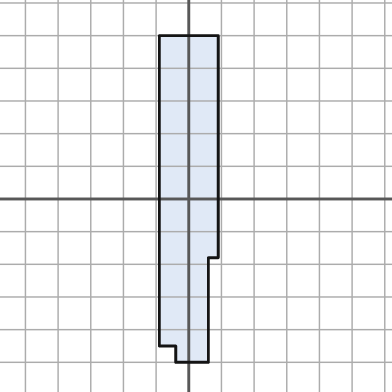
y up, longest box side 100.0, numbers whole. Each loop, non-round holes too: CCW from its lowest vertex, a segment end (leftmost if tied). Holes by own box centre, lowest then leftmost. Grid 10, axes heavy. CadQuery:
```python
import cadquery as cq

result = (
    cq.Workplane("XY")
    .moveTo(-4.0, -50.0)
    .lineTo(6.0, -50.0)
    .lineTo(6.0, -18.0)
    .lineTo(9.0, -18.0)
    .lineTo(9.0, 50.0)
    .lineTo(-9.0, 50.0)
    .lineTo(-9.0, -45.0)
    .lineTo(-4.0, -45.0)
    .close()
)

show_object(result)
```